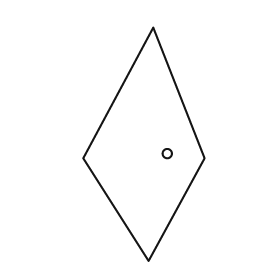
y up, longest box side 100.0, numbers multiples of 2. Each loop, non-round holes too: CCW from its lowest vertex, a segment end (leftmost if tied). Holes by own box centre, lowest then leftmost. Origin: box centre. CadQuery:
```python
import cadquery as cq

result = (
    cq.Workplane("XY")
    .moveTo(2.0, -50.0)
    .lineTo(26.0, -6.0)
    .lineTo(4.0, 50.0)
    .lineTo(-26.0, -6.0)
    .close()
    .moveTo(10.0, -4.0)
    .circle(2.0)
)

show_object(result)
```